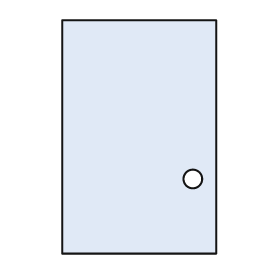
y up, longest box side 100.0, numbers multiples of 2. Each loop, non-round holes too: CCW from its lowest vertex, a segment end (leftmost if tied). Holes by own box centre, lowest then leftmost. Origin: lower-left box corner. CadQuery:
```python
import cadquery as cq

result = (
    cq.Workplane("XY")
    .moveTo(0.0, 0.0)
    .lineTo(66.0, 0.0)
    .lineTo(66.0, 100.0)
    .lineTo(0.0, 100.0)
    .close()
    .moveTo(56.0, 32.0)
    .circle(4.0)
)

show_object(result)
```